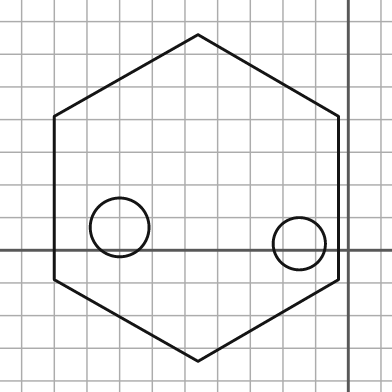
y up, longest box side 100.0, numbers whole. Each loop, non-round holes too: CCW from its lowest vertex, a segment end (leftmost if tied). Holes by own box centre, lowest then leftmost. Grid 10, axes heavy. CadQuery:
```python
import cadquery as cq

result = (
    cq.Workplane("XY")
    .moveTo(-46.0, -34.0)
    .lineTo(-3.0, -9.0)
    .lineTo(-3.0, 41.0)
    .lineTo(-46.0, 66.0)
    .lineTo(-90.0, 41.0)
    .lineTo(-90.0, -9.0)
    .close()
    .moveTo(-15.0, 2.0)
    .circle(8.0)
    .moveTo(-70.0, 7.0)
    .circle(9.0)
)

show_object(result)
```